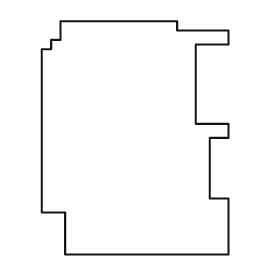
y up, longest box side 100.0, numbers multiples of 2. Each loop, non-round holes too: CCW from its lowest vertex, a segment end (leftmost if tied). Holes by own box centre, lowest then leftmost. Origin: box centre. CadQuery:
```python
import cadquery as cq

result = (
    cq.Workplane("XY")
    .moveTo(-30.0, -50.0)
    .lineTo(40.0, -50.0)
    .lineTo(40.0, -26.0)
    .lineTo(32.0, -26.0)
    .lineTo(32.0, 0.0)
    .lineTo(40.0, 0.0)
    .lineTo(40.0, 6.0)
    .lineTo(26.0, 6.0)
    .lineTo(26.0, 40.0)
    .lineTo(40.0, 40.0)
    .lineTo(40.0, 46.0)
    .lineTo(18.0, 46.0)
    .lineTo(18.0, 50.0)
    .lineTo(-32.0, 50.0)
    .lineTo(-32.0, 42.0)
    .lineTo(-36.0, 42.0)
    .lineTo(-36.0, 38.0)
    .lineTo(-40.0, 38.0)
    .lineTo(-40.0, -32.0)
    .lineTo(-30.0, -32.0)
    .close()
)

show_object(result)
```